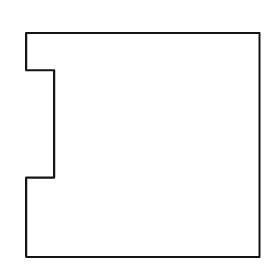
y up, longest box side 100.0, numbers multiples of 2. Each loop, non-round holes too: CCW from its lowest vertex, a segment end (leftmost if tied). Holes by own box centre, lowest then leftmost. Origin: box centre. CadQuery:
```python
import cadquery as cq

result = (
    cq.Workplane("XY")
    .moveTo(-50.0, -48.0)
    .lineTo(50.0, -48.0)
    .lineTo(50.0, 48.0)
    .lineTo(-50.0, 48.0)
    .lineTo(-50.0, 32.0)
    .lineTo(-38.0, 32.0)
    .lineTo(-38.0, -14.0)
    .lineTo(-50.0, -14.0)
    .close()
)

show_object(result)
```